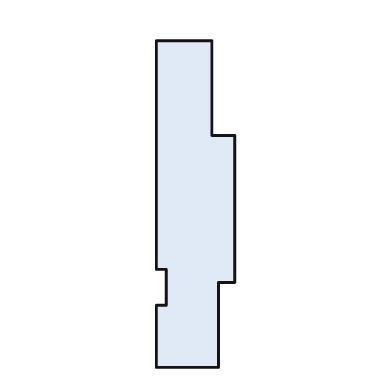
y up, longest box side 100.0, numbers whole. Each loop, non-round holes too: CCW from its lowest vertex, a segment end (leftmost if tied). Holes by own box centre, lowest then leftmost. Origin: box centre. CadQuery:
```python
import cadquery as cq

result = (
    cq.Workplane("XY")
    .moveTo(-12.0, -50.0)
    .lineTo(7.0, -50.0)
    .lineTo(7.0, -24.0)
    .lineTo(12.0, -24.0)
    .lineTo(12.0, 21.0)
    .lineTo(5.0, 21.0)
    .lineTo(5.0, 50.0)
    .lineTo(-12.0, 50.0)
    .lineTo(-12.0, -20.0)
    .lineTo(-9.0, -20.0)
    .lineTo(-9.0, -31.0)
    .lineTo(-12.0, -31.0)
    .close()
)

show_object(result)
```